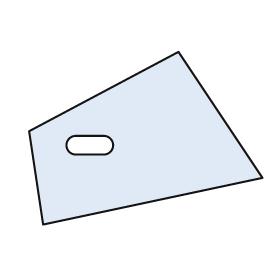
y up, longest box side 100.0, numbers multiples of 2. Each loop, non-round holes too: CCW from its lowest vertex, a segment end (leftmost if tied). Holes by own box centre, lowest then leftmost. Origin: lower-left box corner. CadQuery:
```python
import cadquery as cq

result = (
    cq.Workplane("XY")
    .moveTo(6.0, 0.0)
    .lineTo(100.0, 20.0)
    .lineTo(64.0, 74.0)
    .lineTo(0.0, 40.0)
    .close()
    .moveTo(20.0, 30.0)
    .lineTo(32.0, 30.0)
    .threePointArc((36.0, 34.0), (32.0, 38.0))
    .lineTo(20.0, 38.0)
    .threePointArc((16.0, 34.0), (20.0, 30.0))
    .close()
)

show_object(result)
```